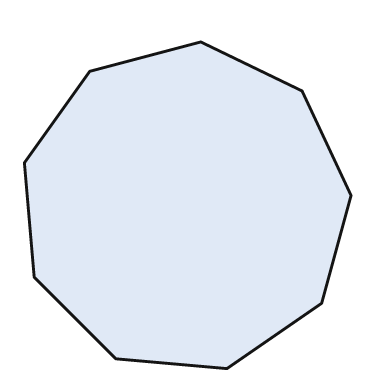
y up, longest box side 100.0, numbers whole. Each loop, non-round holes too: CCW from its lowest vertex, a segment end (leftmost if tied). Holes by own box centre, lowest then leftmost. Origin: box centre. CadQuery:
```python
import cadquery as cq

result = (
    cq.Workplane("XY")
    .moveTo(12.0, -50.0)
    .lineTo(41.0, -30.0)
    .lineTo(50.0, 3.0)
    .lineTo(35.0, 35.0)
    .lineTo(4.0, 50.0)
    .lineTo(-30.0, 41.0)
    .lineTo(-50.0, 13.0)
    .lineTo(-47.0, -22.0)
    .lineTo(-22.0, -47.0)
    .close()
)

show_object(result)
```